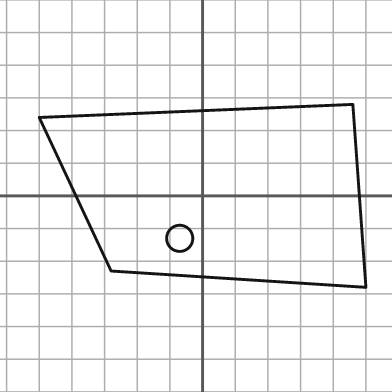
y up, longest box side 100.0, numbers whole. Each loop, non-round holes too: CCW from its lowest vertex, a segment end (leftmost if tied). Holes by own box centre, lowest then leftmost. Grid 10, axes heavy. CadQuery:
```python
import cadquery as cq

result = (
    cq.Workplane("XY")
    .moveTo(50.0, -28.0)
    .lineTo(46.0, 28.0)
    .lineTo(-50.0, 24.0)
    .lineTo(-28.0, -23.0)
    .close()
    .moveTo(-7.0, -13.0)
    .circle(4.0)
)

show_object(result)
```